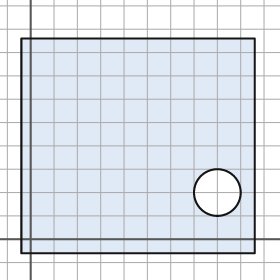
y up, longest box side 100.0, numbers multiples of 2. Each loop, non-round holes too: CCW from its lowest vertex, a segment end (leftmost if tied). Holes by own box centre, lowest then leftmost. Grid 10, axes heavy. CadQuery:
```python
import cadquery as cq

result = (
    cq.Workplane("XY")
    .moveTo(-4.0, -6.0)
    .lineTo(96.0, -6.0)
    .lineTo(96.0, 86.0)
    .lineTo(-4.0, 86.0)
    .close()
    .moveTo(80.0, 20.0)
    .circle(10.0)
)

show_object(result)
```